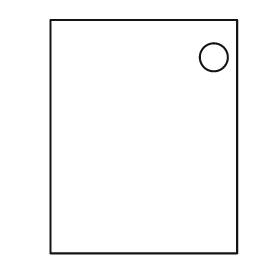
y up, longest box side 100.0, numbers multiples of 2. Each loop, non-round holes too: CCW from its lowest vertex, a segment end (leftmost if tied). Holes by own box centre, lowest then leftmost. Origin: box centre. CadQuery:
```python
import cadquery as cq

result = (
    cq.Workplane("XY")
    .moveTo(-40.0, -50.0)
    .lineTo(40.0, -50.0)
    .lineTo(40.0, 50.0)
    .lineTo(-40.0, 50.0)
    .close()
    .moveTo(30.0, 34.0)
    .circle(6.0)
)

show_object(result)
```